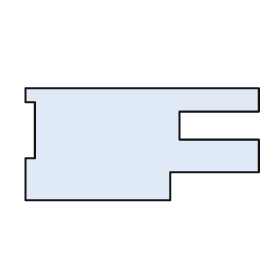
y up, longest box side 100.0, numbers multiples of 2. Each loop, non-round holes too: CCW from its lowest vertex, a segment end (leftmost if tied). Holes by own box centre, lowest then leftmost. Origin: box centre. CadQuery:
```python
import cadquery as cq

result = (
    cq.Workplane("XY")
    .moveTo(-50.0, -24.0)
    .lineTo(12.0, -24.0)
    .lineTo(12.0, -12.0)
    .lineTo(50.0, -12.0)
    .lineTo(50.0, 2.0)
    .lineTo(16.0, 2.0)
    .lineTo(16.0, 14.0)
    .lineTo(50.0, 14.0)
    .lineTo(50.0, 24.0)
    .lineTo(-50.0, 24.0)
    .lineTo(-50.0, 18.0)
    .lineTo(-46.0, 18.0)
    .lineTo(-46.0, -6.0)
    .lineTo(-50.0, -6.0)
    .close()
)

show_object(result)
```